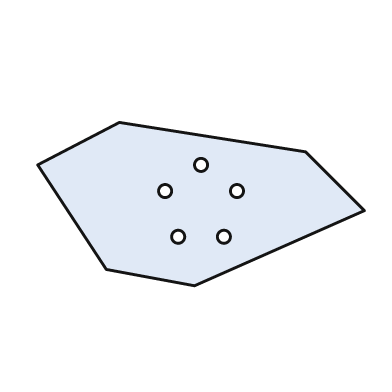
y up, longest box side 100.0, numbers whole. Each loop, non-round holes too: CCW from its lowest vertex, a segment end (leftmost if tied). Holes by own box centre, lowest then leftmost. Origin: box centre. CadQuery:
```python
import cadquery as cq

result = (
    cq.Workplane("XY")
    .moveTo(-2.0, -25.0)
    .lineTo(50.0, -2.0)
    .lineTo(32.0, 16.0)
    .lineTo(-25.0, 25.0)
    .lineTo(-50.0, 12.0)
    .lineTo(-29.0, -20.0)
    .close()
    .moveTo(-7.0, -10.0)
    .circle(2.0)
    .moveTo(7.0, -10.0)
    .circle(2.0)
    .moveTo(-11.0, 4.0)
    .circle(2.0)
    .moveTo(11.0, 4.0)
    .circle(2.0)
    .moveTo(0.0, 12.0)
    .circle(2.0)
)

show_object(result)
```